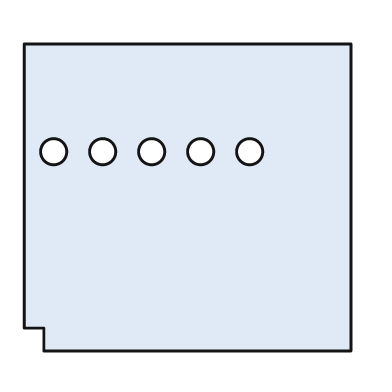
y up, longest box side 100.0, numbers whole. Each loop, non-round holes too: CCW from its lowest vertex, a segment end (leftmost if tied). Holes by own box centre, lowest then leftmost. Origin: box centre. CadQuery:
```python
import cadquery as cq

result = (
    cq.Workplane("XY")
    .moveTo(-44.0, -47.0)
    .lineTo(50.0, -47.0)
    .lineTo(50.0, 47.0)
    .lineTo(-50.0, 47.0)
    .lineTo(-50.0, -40.0)
    .lineTo(-44.0, -40.0)
    .close()
    .moveTo(-41.0, 14.0)
    .circle(4.0)
    .moveTo(-26.0, 14.0)
    .circle(4.0)
    .moveTo(-11.0, 14.0)
    .circle(4.0)
    .moveTo(4.0, 14.0)
    .circle(4.0)
    .moveTo(19.0, 14.0)
    .circle(4.0)
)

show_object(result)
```